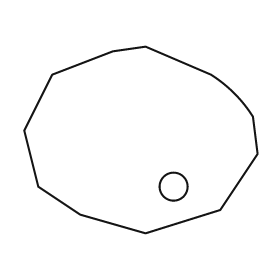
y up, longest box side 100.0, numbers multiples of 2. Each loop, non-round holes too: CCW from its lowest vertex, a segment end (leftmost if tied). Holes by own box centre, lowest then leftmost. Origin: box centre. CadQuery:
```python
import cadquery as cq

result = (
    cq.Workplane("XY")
    .moveTo(2.0, -40.0)
    .lineTo(34.0, -30.0)
    .lineTo(50.0, -6.0)
    .lineTo(48.0, 10.0)
    .threePointArc((40.0, 20.0), (30.0, 28.0))
    .lineTo(2.0, 40.0)
    .lineTo(-12.0, 38.0)
    .lineTo(-38.0, 28.0)
    .lineTo(-50.0, 4.0)
    .lineTo(-44.0, -20.0)
    .lineTo(-26.0, -32.0)
    .close()
    .moveTo(14.0, -20.0)
    .circle(6.0)
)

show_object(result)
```